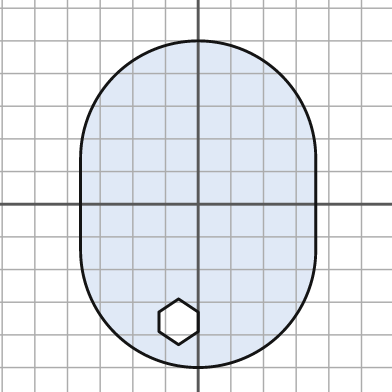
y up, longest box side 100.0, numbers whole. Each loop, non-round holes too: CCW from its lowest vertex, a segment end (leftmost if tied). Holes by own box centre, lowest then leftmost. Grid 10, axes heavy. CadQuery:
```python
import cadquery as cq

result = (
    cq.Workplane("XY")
    .moveTo(-36.0, -14.0)
    .threePointArc((0.0, -50.0), (36.0, -14.0))
    .lineTo(36.0, 14.0)
    .threePointArc((0.0, 50.0), (-36.0, 14.0))
    .close()
    .moveTo(-6.0, -43.0)
    .lineTo(0.0, -39.0)
    .lineTo(0.0, -33.0)
    .lineTo(-6.0, -29.0)
    .lineTo(-12.0, -33.0)
    .lineTo(-12.0, -39.0)
    .close()
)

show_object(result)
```